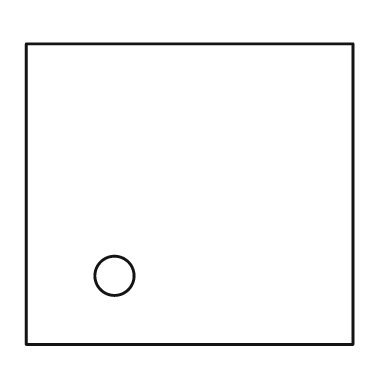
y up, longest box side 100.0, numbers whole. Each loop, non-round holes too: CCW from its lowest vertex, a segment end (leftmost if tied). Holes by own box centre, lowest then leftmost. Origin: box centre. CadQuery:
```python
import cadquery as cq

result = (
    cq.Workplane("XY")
    .moveTo(-50.0, -46.0)
    .lineTo(50.0, -46.0)
    .lineTo(50.0, 46.0)
    .lineTo(-50.0, 46.0)
    .close()
    .moveTo(-23.0, -25.0)
    .circle(6.0)
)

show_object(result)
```